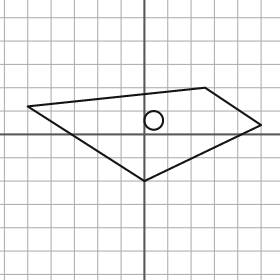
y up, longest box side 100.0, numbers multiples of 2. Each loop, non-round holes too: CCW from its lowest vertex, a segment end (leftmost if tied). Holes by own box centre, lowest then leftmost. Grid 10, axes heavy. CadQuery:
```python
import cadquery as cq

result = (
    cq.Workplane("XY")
    .moveTo(0.0, -20.0)
    .lineTo(50.0, 4.0)
    .lineTo(26.0, 20.0)
    .lineTo(-50.0, 12.0)
    .close()
    .moveTo(4.0, 6.0)
    .circle(4.0)
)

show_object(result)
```